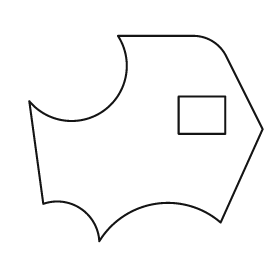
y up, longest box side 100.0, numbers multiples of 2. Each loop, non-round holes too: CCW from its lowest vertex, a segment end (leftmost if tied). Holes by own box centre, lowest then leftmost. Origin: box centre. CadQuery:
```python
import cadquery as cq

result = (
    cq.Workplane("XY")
    .moveTo(-20.0, -44.0)
    .threePointArc((4.0, -28.0), (32.0, -36.0))
    .lineTo(50.0, 4.0)
    .lineTo(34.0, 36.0)
    .threePointArc((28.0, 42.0), (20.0, 44.0))
    .lineTo(-12.0, 44.0)
    .threePointArc((-18.0, 12.0), (-50.0, 16.0))
    .lineTo(-44.0, -28.0)
    .threePointArc((-28.0, -30.0), (-20.0, -44.0))
    .close()
    .moveTo(14.0, 2.0)
    .lineTo(34.0, 2.0)
    .lineTo(34.0, 18.0)
    .lineTo(14.0, 18.0)
    .close()
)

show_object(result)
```